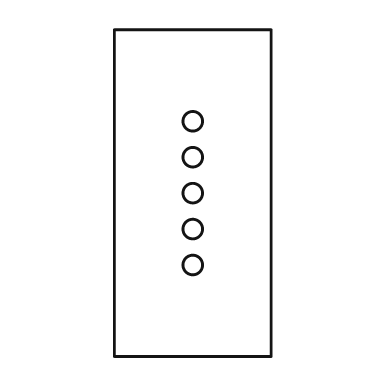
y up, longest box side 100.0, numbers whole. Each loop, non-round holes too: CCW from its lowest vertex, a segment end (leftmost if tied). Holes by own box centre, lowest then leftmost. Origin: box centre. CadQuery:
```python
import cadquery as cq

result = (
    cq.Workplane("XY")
    .moveTo(-24.0, -50.0)
    .lineTo(24.0, -50.0)
    .lineTo(24.0, 50.0)
    .lineTo(-24.0, 50.0)
    .close()
    .moveTo(0.0, -22.0)
    .circle(3.0)
    .moveTo(0.0, -11.0)
    .circle(3.0)
    .moveTo(0.0, 0.0)
    .circle(3.0)
    .moveTo(0.0, 11.0)
    .circle(3.0)
    .moveTo(0.0, 22.0)
    .circle(3.0)
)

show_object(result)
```